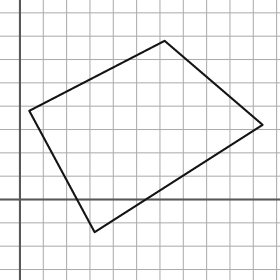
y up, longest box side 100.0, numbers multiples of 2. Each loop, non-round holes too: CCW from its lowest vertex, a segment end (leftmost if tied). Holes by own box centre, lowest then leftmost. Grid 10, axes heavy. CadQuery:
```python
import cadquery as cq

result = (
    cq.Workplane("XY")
    .moveTo(32.0, -14.0)
    .lineTo(104.0, 32.0)
    .lineTo(62.0, 68.0)
    .lineTo(4.0, 38.0)
    .close()
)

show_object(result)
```